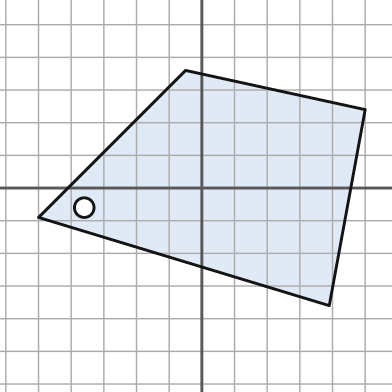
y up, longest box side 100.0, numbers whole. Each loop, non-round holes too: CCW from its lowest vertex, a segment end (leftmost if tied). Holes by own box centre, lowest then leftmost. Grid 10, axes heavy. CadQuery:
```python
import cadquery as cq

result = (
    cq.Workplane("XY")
    .moveTo(39.0, -36.0)
    .lineTo(50.0, 24.0)
    .lineTo(-5.0, 36.0)
    .lineTo(-50.0, -9.0)
    .close()
    .moveTo(-36.0, -6.0)
    .circle(3.0)
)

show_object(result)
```